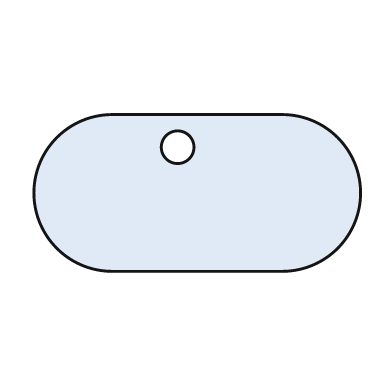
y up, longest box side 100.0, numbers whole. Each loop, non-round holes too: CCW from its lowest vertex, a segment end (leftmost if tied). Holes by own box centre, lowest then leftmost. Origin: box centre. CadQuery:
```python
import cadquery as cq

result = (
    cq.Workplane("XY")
    .moveTo(-26.0, -24.0)
    .lineTo(26.0, -24.0)
    .threePointArc((50.0, 0.0), (26.0, 24.0))
    .lineTo(-26.0, 24.0)
    .threePointArc((-50.0, 0.0), (-26.0, -24.0))
    .close()
    .moveTo(-6.0, 14.0)
    .circle(5.0)
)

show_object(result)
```